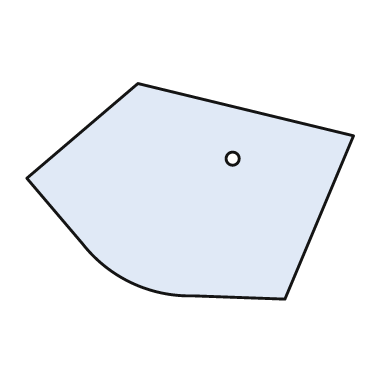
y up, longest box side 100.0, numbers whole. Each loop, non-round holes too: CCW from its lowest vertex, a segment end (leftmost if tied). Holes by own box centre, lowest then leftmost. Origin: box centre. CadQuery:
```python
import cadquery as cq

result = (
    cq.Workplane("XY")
    .moveTo(29.0, -33.0)
    .lineTo(50.0, 17.0)
    .lineTo(-16.0, 33.0)
    .lineTo(-50.0, 4.0)
    .lineTo(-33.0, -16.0)
    .threePointArc((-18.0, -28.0), (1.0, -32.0))
    .close()
    .moveTo(13.0, 10.0)
    .circle(2.0)
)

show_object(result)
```